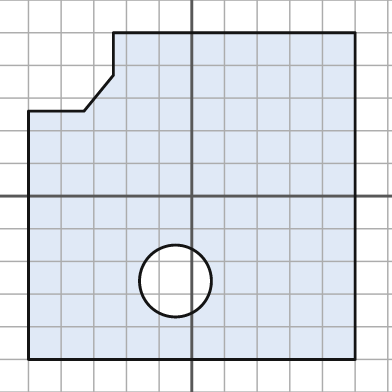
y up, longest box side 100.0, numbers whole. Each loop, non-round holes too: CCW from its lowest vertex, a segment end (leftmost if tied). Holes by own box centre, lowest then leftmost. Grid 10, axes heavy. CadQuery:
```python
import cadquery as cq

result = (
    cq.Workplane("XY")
    .moveTo(-50.0, -50.0)
    .lineTo(50.0, -50.0)
    .lineTo(50.0, 50.0)
    .lineTo(-24.0, 50.0)
    .lineTo(-24.0, 37.0)
    .lineTo(-33.0, 26.0)
    .lineTo(-50.0, 26.0)
    .close()
    .moveTo(-5.0, -26.0)
    .circle(11.0)
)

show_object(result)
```